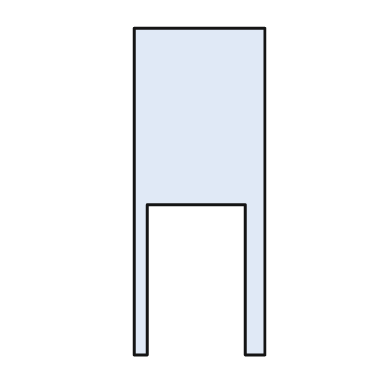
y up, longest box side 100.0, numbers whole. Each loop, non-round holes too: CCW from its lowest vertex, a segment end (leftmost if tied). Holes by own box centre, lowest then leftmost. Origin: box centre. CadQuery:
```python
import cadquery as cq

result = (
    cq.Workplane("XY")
    .moveTo(-20.0, -50.0)
    .lineTo(-16.0, -50.0)
    .lineTo(-16.0, -4.0)
    .lineTo(14.0, -4.0)
    .lineTo(14.0, -50.0)
    .lineTo(20.0, -50.0)
    .lineTo(20.0, 50.0)
    .lineTo(-20.0, 50.0)
    .close()
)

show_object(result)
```